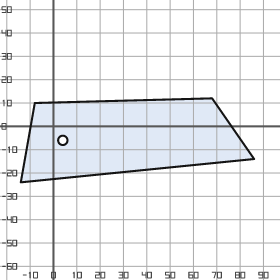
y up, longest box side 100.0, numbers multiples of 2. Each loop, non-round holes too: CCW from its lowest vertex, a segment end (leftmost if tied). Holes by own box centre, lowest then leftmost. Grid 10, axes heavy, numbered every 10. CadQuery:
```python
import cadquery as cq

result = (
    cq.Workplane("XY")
    .moveTo(-14.0, -24.0)
    .lineTo(86.0, -14.0)
    .lineTo(68.0, 12.0)
    .lineTo(-8.0, 10.0)
    .close()
    .moveTo(4.0, -6.0)
    .circle(2.0)
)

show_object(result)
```